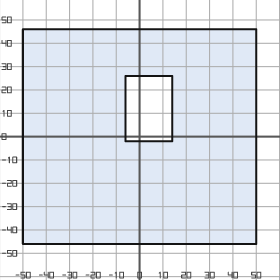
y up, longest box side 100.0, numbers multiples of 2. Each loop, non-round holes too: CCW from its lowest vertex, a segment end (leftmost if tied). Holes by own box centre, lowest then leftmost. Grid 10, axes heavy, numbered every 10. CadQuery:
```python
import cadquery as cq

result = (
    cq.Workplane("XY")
    .moveTo(-50.0, -46.0)
    .lineTo(50.0, -46.0)
    .lineTo(50.0, 46.0)
    .lineTo(-50.0, 46.0)
    .close()
    .moveTo(-6.0, -2.0)
    .lineTo(14.0, -2.0)
    .lineTo(14.0, 26.0)
    .lineTo(-6.0, 26.0)
    .close()
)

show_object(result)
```